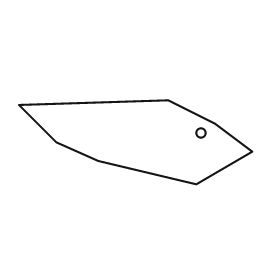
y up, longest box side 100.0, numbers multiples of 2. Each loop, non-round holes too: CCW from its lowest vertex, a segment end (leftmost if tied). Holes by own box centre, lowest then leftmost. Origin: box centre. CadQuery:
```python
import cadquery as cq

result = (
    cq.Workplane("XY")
    .moveTo(26.0, -18.0)
    .lineTo(50.0, -4.0)
    .lineTo(34.0, 8.0)
    .lineTo(14.0, 18.0)
    .lineTo(-50.0, 16.0)
    .lineTo(-34.0, 0.0)
    .lineTo(-16.0, -8.0)
    .close()
    .moveTo(28.0, 4.0)
    .circle(2.0)
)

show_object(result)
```